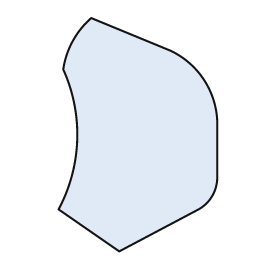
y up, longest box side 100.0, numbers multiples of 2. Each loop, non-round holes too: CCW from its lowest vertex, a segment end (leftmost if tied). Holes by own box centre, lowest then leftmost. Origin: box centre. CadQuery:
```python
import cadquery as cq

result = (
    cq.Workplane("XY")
    .moveTo(-8.0, -50.0)
    .lineTo(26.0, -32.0)
    .threePointArc((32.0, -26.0), (34.0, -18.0))
    .lineTo(34.0, 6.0)
    .threePointArc((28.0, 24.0), (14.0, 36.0))
    .lineTo(-20.0, 50.0)
    .threePointArc((-28.0, 40.0), (-32.0, 28.0))
    .threePointArc((-26.0, -2.0), (-34.0, -32.0))
    .close()
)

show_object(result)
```